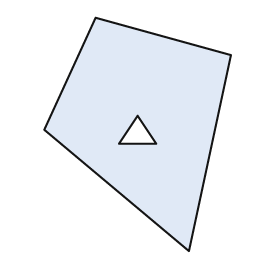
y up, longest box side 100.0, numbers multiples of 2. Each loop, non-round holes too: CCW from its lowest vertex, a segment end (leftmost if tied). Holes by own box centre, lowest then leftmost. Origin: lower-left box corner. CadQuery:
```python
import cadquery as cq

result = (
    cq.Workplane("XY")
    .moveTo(62.0, 0.0)
    .lineTo(80.0, 84.0)
    .lineTo(22.0, 100.0)
    .lineTo(0.0, 52.0)
    .close()
    .moveTo(32.0, 46.0)
    .lineTo(48.0, 46.0)
    .lineTo(40.0, 58.0)
    .close()
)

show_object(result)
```